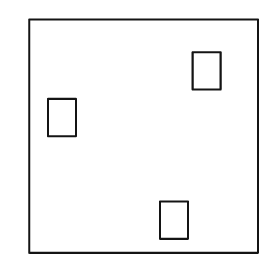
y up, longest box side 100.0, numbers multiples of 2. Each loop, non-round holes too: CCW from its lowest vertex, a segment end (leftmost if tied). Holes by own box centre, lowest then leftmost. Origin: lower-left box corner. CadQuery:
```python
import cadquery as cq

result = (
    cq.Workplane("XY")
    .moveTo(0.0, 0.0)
    .lineTo(98.0, 0.0)
    .lineTo(98.0, 100.0)
    .lineTo(0.0, 100.0)
    .close()
    .moveTo(56.0, 6.0)
    .lineTo(68.0, 6.0)
    .lineTo(68.0, 22.0)
    .lineTo(56.0, 22.0)
    .close()
    .moveTo(8.0, 50.0)
    .lineTo(20.0, 50.0)
    .lineTo(20.0, 66.0)
    .lineTo(8.0, 66.0)
    .close()
    .moveTo(70.0, 70.0)
    .lineTo(82.0, 70.0)
    .lineTo(82.0, 86.0)
    .lineTo(70.0, 86.0)
    .close()
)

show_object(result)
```